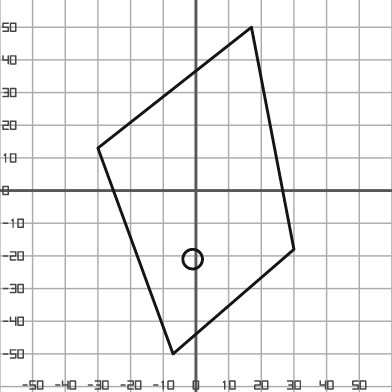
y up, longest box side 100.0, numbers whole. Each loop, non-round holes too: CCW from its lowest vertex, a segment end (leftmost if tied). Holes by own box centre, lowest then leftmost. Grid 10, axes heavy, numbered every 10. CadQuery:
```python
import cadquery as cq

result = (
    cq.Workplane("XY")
    .moveTo(-7.0, -50.0)
    .lineTo(30.0, -18.0)
    .lineTo(17.0, 50.0)
    .lineTo(-30.0, 13.0)
    .close()
    .moveTo(-1.0, -21.0)
    .circle(3.0)
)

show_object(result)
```